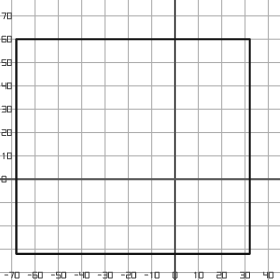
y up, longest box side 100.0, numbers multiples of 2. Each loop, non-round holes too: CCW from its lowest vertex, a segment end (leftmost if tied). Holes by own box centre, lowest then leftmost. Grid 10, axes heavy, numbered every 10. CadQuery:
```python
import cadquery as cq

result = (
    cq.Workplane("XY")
    .moveTo(-68.0, -32.0)
    .lineTo(32.0, -32.0)
    .lineTo(32.0, 60.0)
    .lineTo(-68.0, 60.0)
    .close()
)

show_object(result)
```